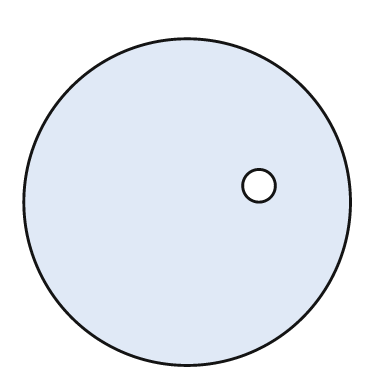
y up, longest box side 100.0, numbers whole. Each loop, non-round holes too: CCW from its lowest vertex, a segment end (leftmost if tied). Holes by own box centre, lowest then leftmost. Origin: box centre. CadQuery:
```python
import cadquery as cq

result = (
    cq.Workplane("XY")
    .moveTo(0.0, 0.0)
    .circle(50.0)
    .moveTo(22.0, 5.0)
    .circle(5.0)
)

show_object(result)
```